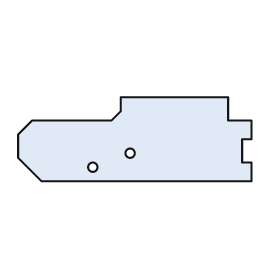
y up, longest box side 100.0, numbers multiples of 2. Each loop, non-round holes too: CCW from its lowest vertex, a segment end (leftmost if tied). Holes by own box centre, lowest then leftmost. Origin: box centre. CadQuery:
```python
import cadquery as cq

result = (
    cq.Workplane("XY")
    .moveTo(-40.0, -18.0)
    .lineTo(50.0, -18.0)
    .lineTo(50.0, -10.0)
    .lineTo(46.0, -10.0)
    .lineTo(46.0, 0.0)
    .lineTo(50.0, 0.0)
    .lineTo(50.0, 8.0)
    .lineTo(40.0, 8.0)
    .lineTo(40.0, 18.0)
    .lineTo(-6.0, 18.0)
    .lineTo(-6.0, 12.0)
    .lineTo(-10.0, 8.0)
    .lineTo(-44.0, 8.0)
    .lineTo(-50.0, 2.0)
    .lineTo(-50.0, -8.0)
    .close()
    .moveTo(-18.0, -12.0)
    .circle(2.0)
    .moveTo(-2.0, -6.0)
    .circle(2.0)
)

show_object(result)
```